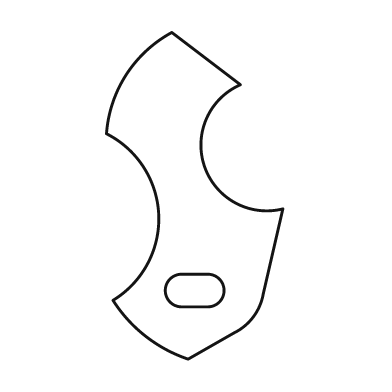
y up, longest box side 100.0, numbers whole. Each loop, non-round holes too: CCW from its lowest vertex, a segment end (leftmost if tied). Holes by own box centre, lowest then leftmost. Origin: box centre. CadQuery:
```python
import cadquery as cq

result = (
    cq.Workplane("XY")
    .moveTo(-2.0, -50.0)
    .lineTo(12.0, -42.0)
    .threePointArc((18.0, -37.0), (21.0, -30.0))
    .lineTo(27.0, -4.0)
    .threePointArc((3.0, 9.0), (14.0, 34.0))
    .lineTo(-7.0, 50.0)
    .threePointArc((-21.0, 37.0), (-27.0, 19.0))
    .threePointArc((-11.0, -6.0), (-25.0, -32.0))
    .threePointArc((-15.0, -43.0), (-2.0, -50.0))
    .close()
    .moveTo(-4.0, -34.0)
    .lineTo(4.0, -34.0)
    .threePointArc((9.0, -29.0), (4.0, -24.0))
    .lineTo(-4.0, -24.0)
    .threePointArc((-9.0, -29.0), (-4.0, -34.0))
    .close()
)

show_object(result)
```